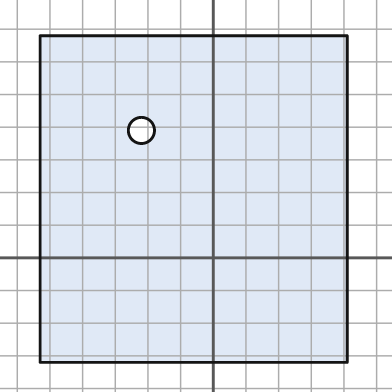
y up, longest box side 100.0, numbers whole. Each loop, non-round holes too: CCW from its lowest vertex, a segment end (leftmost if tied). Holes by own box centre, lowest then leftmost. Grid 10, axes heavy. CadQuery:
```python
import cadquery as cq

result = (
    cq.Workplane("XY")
    .moveTo(-53.0, -32.0)
    .lineTo(41.0, -32.0)
    .lineTo(41.0, 68.0)
    .lineTo(-53.0, 68.0)
    .close()
    .moveTo(-22.0, 39.0)
    .circle(4.0)
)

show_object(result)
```